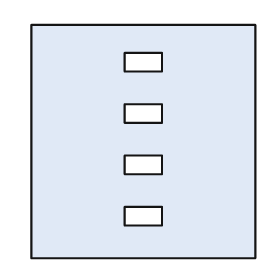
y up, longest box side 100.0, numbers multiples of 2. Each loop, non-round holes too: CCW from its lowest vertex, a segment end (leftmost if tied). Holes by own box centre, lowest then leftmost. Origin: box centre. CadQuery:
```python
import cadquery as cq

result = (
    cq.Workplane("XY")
    .moveTo(-48.0, -50.0)
    .lineTo(48.0, -50.0)
    .lineTo(48.0, 50.0)
    .lineTo(-48.0, 50.0)
    .close()
    .moveTo(-8.0, -36.0)
    .lineTo(8.0, -36.0)
    .lineTo(8.0, -28.0)
    .lineTo(-8.0, -28.0)
    .close()
    .moveTo(-8.0, -14.0)
    .lineTo(8.0, -14.0)
    .lineTo(8.0, -6.0)
    .lineTo(-8.0, -6.0)
    .close()
    .moveTo(-8.0, 8.0)
    .lineTo(8.0, 8.0)
    .lineTo(8.0, 16.0)
    .lineTo(-8.0, 16.0)
    .close()
    .moveTo(-8.0, 30.0)
    .lineTo(8.0, 30.0)
    .lineTo(8.0, 38.0)
    .lineTo(-8.0, 38.0)
    .close()
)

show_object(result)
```